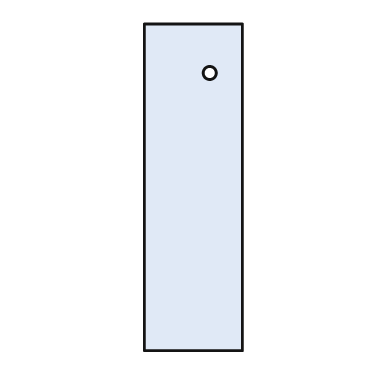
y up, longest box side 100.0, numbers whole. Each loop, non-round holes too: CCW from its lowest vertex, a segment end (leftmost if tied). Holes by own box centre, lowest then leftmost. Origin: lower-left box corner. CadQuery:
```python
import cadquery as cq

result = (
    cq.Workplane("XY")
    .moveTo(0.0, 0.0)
    .lineTo(30.0, 0.0)
    .lineTo(30.0, 100.0)
    .lineTo(0.0, 100.0)
    .close()
    .moveTo(20.0, 85.0)
    .circle(2.0)
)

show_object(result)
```